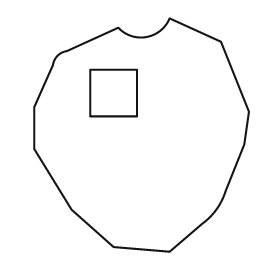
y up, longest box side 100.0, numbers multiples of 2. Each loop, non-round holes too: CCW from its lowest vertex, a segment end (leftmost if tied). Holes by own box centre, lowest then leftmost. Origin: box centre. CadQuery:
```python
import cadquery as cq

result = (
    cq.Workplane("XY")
    .moveTo(12.0, -50.0)
    .lineTo(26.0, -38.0)
    .threePointArc((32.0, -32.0), (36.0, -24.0))
    .lineTo(44.0, -4.0)
    .lineTo(46.0, 10.0)
    .lineTo(34.0, 40.0)
    .lineTo(12.0, 50.0)
    .threePointArc((2.0, 42.0), (-10.0, 46.0))
    .lineTo(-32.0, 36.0)
    .threePointArc((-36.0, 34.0), (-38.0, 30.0))
    .lineTo(-46.0, 12.0)
    .lineTo(-46.0, -6.0)
    .lineTo(-30.0, -32.0)
    .lineTo(-12.0, -48.0)
    .close()
    .moveTo(-22.0, 8.0)
    .lineTo(-2.0, 8.0)
    .lineTo(-2.0, 28.0)
    .lineTo(-22.0, 28.0)
    .close()
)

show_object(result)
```